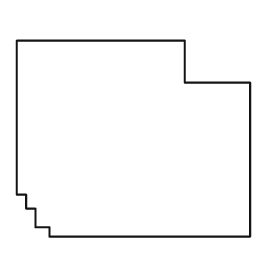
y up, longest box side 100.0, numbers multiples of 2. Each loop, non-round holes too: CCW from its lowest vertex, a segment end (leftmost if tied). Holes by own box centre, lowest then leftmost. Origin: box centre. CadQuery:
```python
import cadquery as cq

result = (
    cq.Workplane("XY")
    .moveTo(-36.0, -42.0)
    .lineTo(50.0, -42.0)
    .lineTo(50.0, 24.0)
    .lineTo(22.0, 24.0)
    .lineTo(22.0, 42.0)
    .lineTo(-50.0, 42.0)
    .lineTo(-50.0, -24.0)
    .lineTo(-46.0, -24.0)
    .lineTo(-46.0, -30.0)
    .lineTo(-42.0, -30.0)
    .lineTo(-42.0, -38.0)
    .lineTo(-36.0, -38.0)
    .close()
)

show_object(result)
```